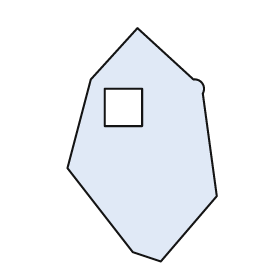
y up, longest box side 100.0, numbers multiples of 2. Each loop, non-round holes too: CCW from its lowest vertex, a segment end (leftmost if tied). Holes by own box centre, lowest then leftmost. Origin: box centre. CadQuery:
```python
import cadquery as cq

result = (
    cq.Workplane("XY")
    .moveTo(8.0, -50.0)
    .lineTo(32.0, -22.0)
    .lineTo(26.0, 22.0)
    .threePointArc((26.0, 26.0), (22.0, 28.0))
    .lineTo(-2.0, 50.0)
    .lineTo(-22.0, 28.0)
    .lineTo(-32.0, -10.0)
    .lineTo(-4.0, -46.0)
    .close()
    .moveTo(-16.0, 8.0)
    .lineTo(0.0, 8.0)
    .lineTo(0.0, 24.0)
    .lineTo(-16.0, 24.0)
    .close()
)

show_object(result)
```